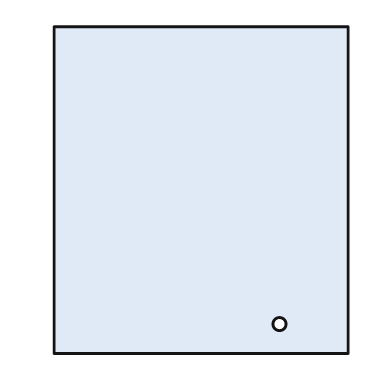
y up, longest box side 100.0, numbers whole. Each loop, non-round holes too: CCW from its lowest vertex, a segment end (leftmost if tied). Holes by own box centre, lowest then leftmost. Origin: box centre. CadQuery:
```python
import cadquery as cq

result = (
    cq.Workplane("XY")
    .moveTo(-45.0, -50.0)
    .lineTo(45.0, -50.0)
    .lineTo(45.0, 50.0)
    .lineTo(-45.0, 50.0)
    .close()
    .moveTo(24.0, -41.0)
    .circle(2.0)
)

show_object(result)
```